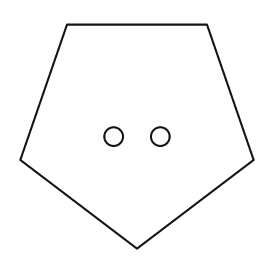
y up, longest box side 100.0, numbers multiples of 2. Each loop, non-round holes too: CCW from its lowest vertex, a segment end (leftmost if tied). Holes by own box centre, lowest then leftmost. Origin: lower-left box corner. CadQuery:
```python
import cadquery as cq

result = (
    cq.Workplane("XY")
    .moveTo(50.0, 0.0)
    .lineTo(100.0, 38.0)
    .lineTo(80.0, 96.0)
    .lineTo(20.0, 96.0)
    .lineTo(0.0, 38.0)
    .close()
    .moveTo(40.0, 48.0)
    .circle(4.0)
    .moveTo(60.0, 48.0)
    .circle(4.0)
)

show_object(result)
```